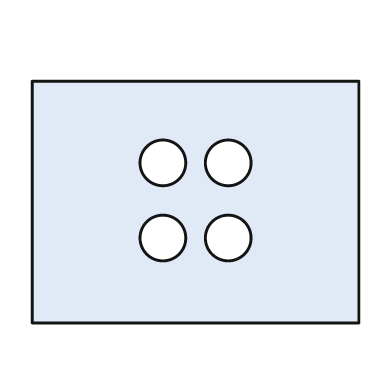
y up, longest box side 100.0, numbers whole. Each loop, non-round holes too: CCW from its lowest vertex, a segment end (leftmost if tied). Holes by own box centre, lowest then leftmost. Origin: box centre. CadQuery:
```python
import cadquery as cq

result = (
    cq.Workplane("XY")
    .moveTo(-50.0, -37.0)
    .lineTo(50.0, -37.0)
    .lineTo(50.0, 37.0)
    .lineTo(-50.0, 37.0)
    .close()
    .moveTo(-10.0, -11.0)
    .circle(7.0)
    .moveTo(10.0, -11.0)
    .circle(7.0)
    .moveTo(-10.0, 12.0)
    .circle(7.0)
    .moveTo(10.0, 12.0)
    .circle(7.0)
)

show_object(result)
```